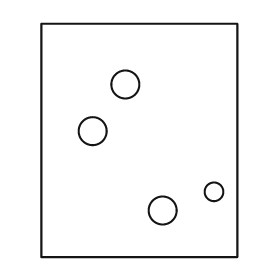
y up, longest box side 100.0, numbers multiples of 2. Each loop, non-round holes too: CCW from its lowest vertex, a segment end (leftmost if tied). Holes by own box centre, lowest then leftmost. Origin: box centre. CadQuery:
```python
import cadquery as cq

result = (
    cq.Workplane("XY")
    .moveTo(-42.0, -50.0)
    .lineTo(42.0, -50.0)
    .lineTo(42.0, 50.0)
    .lineTo(-42.0, 50.0)
    .close()
    .moveTo(10.0, -30.0)
    .circle(6.0)
    .moveTo(32.0, -22.0)
    .circle(4.0)
    .moveTo(-20.0, 4.0)
    .circle(6.0)
    .moveTo(-6.0, 24.0)
    .circle(6.0)
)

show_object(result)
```